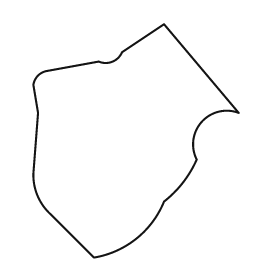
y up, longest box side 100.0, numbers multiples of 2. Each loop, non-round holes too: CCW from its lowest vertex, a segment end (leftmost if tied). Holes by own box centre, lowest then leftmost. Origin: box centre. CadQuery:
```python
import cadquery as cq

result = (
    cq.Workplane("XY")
    .moveTo(-18.0, -50.0)
    .threePointArc((0.0, -42.0), (12.0, -26.0))
    .threePointArc((20.0, -18.0), (26.0, -8.0))
    .threePointArc((28.0, 8.0), (44.0, 12.0))
    .lineTo(12.0, 50.0)
    .lineTo(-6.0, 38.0)
    .threePointArc((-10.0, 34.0), (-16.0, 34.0))
    .lineTo(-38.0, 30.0)
    .threePointArc((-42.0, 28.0), (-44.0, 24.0))
    .lineTo(-42.0, 12.0)
    .lineTo(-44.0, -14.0)
    .threePointArc((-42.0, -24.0), (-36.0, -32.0))
    .close()
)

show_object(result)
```